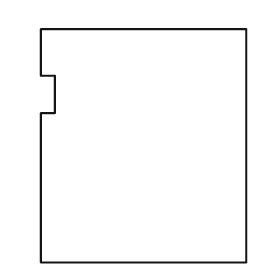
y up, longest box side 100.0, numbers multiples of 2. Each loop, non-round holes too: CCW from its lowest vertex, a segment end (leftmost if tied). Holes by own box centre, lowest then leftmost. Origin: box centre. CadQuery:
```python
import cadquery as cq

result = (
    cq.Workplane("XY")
    .moveTo(-44.0, -50.0)
    .lineTo(44.0, -50.0)
    .lineTo(44.0, 50.0)
    .lineTo(-44.0, 50.0)
    .lineTo(-44.0, 30.0)
    .lineTo(-38.0, 30.0)
    .lineTo(-38.0, 14.0)
    .lineTo(-44.0, 14.0)
    .close()
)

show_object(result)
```